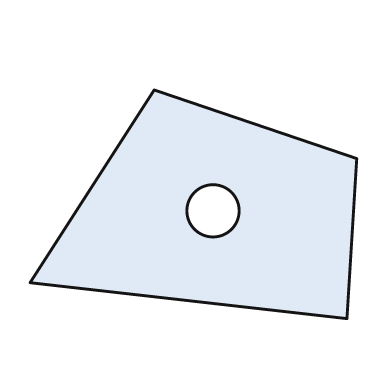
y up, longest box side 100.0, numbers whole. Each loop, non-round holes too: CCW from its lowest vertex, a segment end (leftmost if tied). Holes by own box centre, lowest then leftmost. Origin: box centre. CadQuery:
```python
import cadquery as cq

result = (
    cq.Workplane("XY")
    .moveTo(47.0, -35.0)
    .lineTo(50.0, 14.0)
    .lineTo(-12.0, 35.0)
    .lineTo(-50.0, -24.0)
    .close()
    .moveTo(6.0, -2.0)
    .circle(8.0)
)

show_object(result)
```